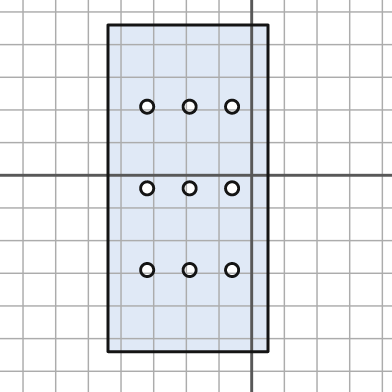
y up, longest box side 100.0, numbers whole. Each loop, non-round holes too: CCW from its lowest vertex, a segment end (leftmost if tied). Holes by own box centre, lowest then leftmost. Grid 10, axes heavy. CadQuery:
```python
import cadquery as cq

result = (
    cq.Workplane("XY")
    .moveTo(-44.0, -54.0)
    .lineTo(5.0, -54.0)
    .lineTo(5.0, 46.0)
    .lineTo(-44.0, 46.0)
    .close()
    .moveTo(-32.0, -29.0)
    .circle(2.0)
    .moveTo(-19.0, -29.0)
    .circle(2.0)
    .moveTo(-6.0, -29.0)
    .circle(2.0)
    .moveTo(-32.0, -4.0)
    .circle(2.0)
    .moveTo(-19.0, -4.0)
    .circle(2.0)
    .moveTo(-6.0, -4.0)
    .circle(2.0)
    .moveTo(-32.0, 21.0)
    .circle(2.0)
    .moveTo(-19.0, 21.0)
    .circle(2.0)
    .moveTo(-6.0, 21.0)
    .circle(2.0)
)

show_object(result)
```